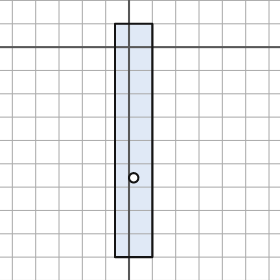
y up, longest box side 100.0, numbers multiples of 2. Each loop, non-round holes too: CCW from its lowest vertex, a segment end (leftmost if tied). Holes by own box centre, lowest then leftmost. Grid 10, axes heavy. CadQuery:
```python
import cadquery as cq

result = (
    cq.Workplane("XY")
    .moveTo(-6.0, -90.0)
    .lineTo(10.0, -90.0)
    .lineTo(10.0, 10.0)
    .lineTo(-6.0, 10.0)
    .close()
    .moveTo(2.0, -56.0)
    .circle(2.0)
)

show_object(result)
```